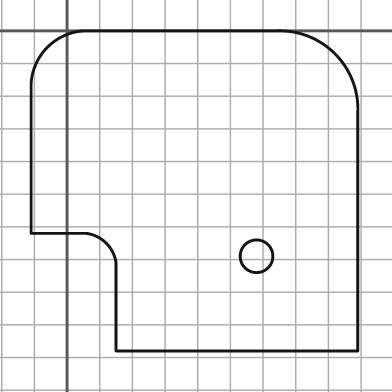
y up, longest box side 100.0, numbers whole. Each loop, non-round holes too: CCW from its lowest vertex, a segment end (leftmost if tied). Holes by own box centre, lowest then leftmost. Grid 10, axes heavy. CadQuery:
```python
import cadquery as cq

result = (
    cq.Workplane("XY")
    .moveTo(15.0, -98.0)
    .lineTo(89.0, -98.0)
    .lineTo(89.0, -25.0)
    .threePointArc((82.0, -7.0), (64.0, 0.0))
    .lineTo(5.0, 0.0)
    .threePointArc((-6.0, -5.0), (-11.0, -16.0))
    .lineTo(-11.0, -62.0)
    .lineTo(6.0, -62.0)
    .threePointArc((12.0, -65.0), (15.0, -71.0))
    .close()
    .moveTo(58.0, -69.0)
    .circle(5.0)
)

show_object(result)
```